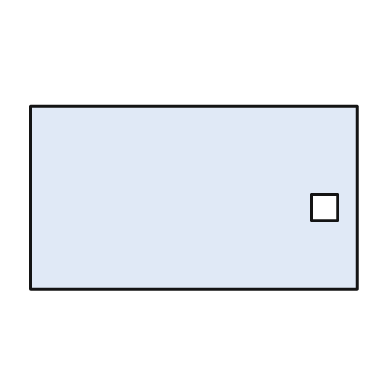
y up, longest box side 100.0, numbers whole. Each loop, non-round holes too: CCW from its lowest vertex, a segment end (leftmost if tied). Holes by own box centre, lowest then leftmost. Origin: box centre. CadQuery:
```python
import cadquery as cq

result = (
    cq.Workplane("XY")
    .moveTo(-50.0, -28.0)
    .lineTo(50.0, -28.0)
    .lineTo(50.0, 28.0)
    .lineTo(-50.0, 28.0)
    .close()
    .moveTo(36.0, -7.0)
    .lineTo(44.0, -7.0)
    .lineTo(44.0, 1.0)
    .lineTo(36.0, 1.0)
    .close()
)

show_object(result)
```